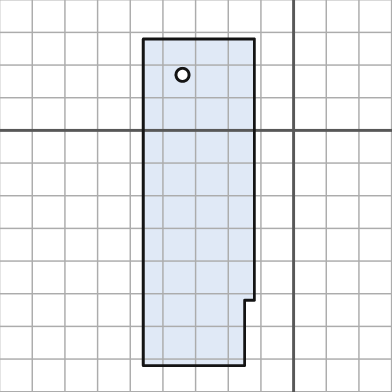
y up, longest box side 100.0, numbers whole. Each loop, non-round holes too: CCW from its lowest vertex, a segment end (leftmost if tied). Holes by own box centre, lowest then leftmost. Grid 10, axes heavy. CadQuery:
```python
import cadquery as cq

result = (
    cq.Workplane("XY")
    .moveTo(-46.0, -72.0)
    .lineTo(-15.0, -72.0)
    .lineTo(-15.0, -52.0)
    .lineTo(-12.0, -52.0)
    .lineTo(-12.0, 28.0)
    .lineTo(-46.0, 28.0)
    .close()
    .moveTo(-34.0, 17.0)
    .circle(2.0)
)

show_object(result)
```